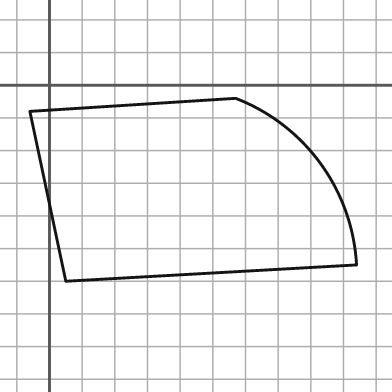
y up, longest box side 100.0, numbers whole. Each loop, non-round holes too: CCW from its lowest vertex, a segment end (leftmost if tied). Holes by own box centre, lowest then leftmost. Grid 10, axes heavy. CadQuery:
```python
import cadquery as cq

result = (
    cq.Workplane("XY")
    .moveTo(5.0, -60.0)
    .lineTo(94.0, -55.0)
    .threePointArc((83.0, -24.0), (57.0, -4.0))
    .lineTo(-6.0, -8.0)
    .close()
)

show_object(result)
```